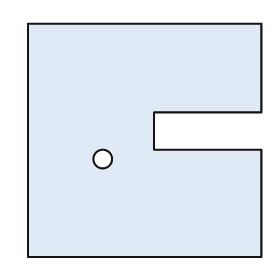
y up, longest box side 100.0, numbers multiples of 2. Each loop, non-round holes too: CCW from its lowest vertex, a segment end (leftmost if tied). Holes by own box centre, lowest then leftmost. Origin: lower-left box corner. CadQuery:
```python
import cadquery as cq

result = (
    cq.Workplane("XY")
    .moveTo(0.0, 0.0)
    .lineTo(100.0, 0.0)
    .lineTo(100.0, 46.0)
    .lineTo(54.0, 46.0)
    .lineTo(54.0, 62.0)
    .lineTo(100.0, 62.0)
    .lineTo(100.0, 100.0)
    .lineTo(0.0, 100.0)
    .close()
    .moveTo(32.0, 42.0)
    .circle(4.0)
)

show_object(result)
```